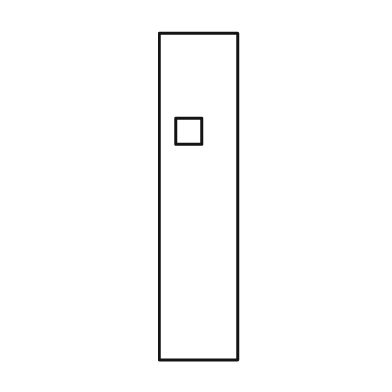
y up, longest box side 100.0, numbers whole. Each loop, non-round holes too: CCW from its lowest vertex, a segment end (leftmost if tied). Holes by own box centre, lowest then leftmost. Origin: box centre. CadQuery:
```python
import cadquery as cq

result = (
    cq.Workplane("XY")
    .moveTo(-12.0, -50.0)
    .lineTo(12.0, -50.0)
    .lineTo(12.0, 50.0)
    .lineTo(-12.0, 50.0)
    .close()
    .moveTo(-7.0, 16.0)
    .lineTo(1.0, 16.0)
    .lineTo(1.0, 24.0)
    .lineTo(-7.0, 24.0)
    .close()
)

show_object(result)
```